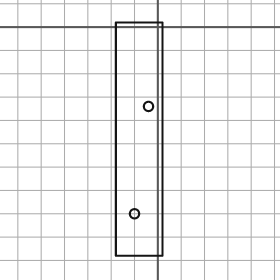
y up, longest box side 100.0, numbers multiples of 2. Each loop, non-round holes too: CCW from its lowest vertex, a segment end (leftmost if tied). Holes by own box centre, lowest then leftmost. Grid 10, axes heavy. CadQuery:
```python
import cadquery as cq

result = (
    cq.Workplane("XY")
    .moveTo(-18.0, -98.0)
    .lineTo(2.0, -98.0)
    .lineTo(2.0, 2.0)
    .lineTo(-18.0, 2.0)
    .close()
    .moveTo(-10.0, -80.0)
    .circle(2.0)
    .moveTo(-4.0, -34.0)
    .circle(2.0)
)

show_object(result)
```